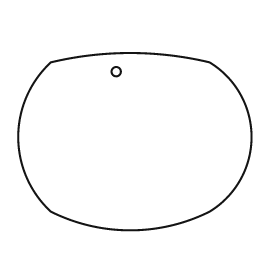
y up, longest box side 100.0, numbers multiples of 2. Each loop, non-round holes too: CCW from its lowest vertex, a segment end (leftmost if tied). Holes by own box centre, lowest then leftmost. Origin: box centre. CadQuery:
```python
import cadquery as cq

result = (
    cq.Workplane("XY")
    .moveTo(-36.0, -30.0)
    .threePointArc((-2.0, -38.0), (32.0, -30.0))
    .threePointArc((50.0, 2.0), (32.0, 34.0))
    .threePointArc((-2.0, 38.0), (-36.0, 34.0))
    .threePointArc((-50.0, 2.0), (-36.0, -30.0))
    .close()
    .moveTo(-8.0, 30.0)
    .circle(2.0)
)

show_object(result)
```